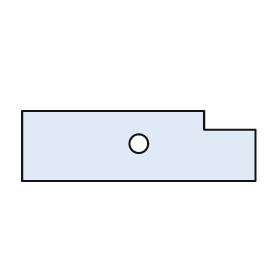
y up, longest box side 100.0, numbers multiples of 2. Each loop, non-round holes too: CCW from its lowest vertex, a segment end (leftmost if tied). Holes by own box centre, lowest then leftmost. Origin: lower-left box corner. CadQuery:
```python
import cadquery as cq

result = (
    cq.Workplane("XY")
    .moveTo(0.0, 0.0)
    .lineTo(100.0, 0.0)
    .lineTo(100.0, 22.0)
    .lineTo(78.0, 22.0)
    .lineTo(78.0, 30.0)
    .lineTo(0.0, 30.0)
    .close()
    .moveTo(50.0, 16.0)
    .circle(4.0)
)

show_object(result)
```